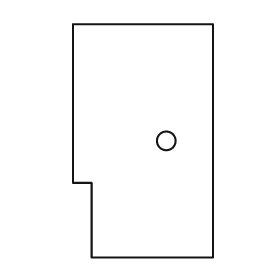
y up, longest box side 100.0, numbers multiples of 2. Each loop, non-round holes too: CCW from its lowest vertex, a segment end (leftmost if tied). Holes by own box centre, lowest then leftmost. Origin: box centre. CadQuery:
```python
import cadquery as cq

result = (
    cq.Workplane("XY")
    .moveTo(-22.0, -50.0)
    .lineTo(30.0, -50.0)
    .lineTo(30.0, 50.0)
    .lineTo(-30.0, 50.0)
    .lineTo(-30.0, -18.0)
    .lineTo(-22.0, -18.0)
    .close()
    .moveTo(10.0, 0.0)
    .circle(4.0)
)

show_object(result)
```